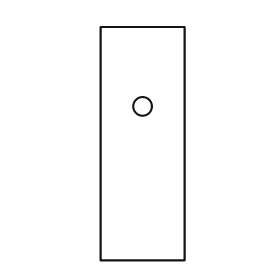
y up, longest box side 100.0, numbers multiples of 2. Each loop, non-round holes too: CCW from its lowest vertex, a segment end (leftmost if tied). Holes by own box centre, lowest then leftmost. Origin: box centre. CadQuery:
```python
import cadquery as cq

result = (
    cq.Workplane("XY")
    .moveTo(-18.0, -50.0)
    .lineTo(18.0, -50.0)
    .lineTo(18.0, 50.0)
    .lineTo(-18.0, 50.0)
    .close()
    .moveTo(0.0, 16.0)
    .circle(4.0)
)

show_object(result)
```